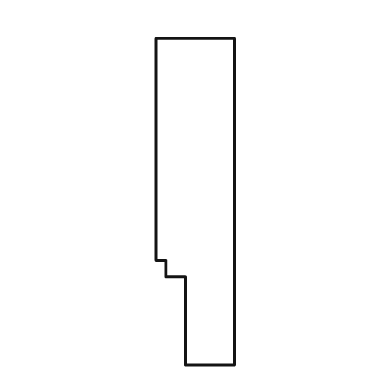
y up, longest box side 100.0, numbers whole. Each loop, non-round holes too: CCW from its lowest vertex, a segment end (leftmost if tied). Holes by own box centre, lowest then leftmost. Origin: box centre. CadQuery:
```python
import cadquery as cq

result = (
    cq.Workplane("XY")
    .moveTo(-3.0, -50.0)
    .lineTo(12.0, -50.0)
    .lineTo(12.0, 50.0)
    .lineTo(-12.0, 50.0)
    .lineTo(-12.0, -18.0)
    .lineTo(-9.0, -18.0)
    .lineTo(-9.0, -23.0)
    .lineTo(-3.0, -23.0)
    .close()
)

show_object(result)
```